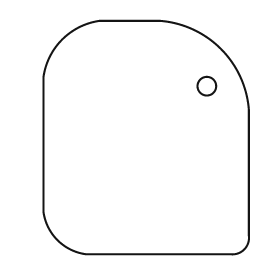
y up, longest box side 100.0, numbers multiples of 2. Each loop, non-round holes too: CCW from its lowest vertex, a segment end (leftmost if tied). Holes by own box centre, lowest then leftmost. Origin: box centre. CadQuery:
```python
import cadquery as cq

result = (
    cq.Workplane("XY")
    .moveTo(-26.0, -50.0)
    .lineTo(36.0, -50.0)
    .threePointArc((42.0, -48.0), (44.0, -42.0))
    .lineTo(44.0, 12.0)
    .threePointArc((32.0, 38.0), (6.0, 50.0))
    .lineTo(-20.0, 50.0)
    .threePointArc((-36.0, 42.0), (-44.0, 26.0))
    .lineTo(-44.0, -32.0)
    .threePointArc((-38.0, -44.0), (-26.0, -50.0))
    .close()
    .moveTo(26.0, 22.0)
    .circle(4.0)
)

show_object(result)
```